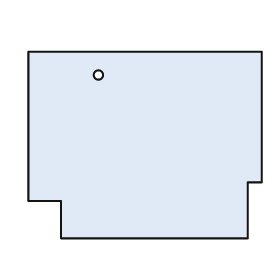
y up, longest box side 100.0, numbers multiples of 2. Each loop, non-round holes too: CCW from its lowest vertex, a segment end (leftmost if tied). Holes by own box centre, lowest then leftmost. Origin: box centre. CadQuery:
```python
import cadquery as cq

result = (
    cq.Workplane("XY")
    .moveTo(-36.0, -40.0)
    .lineTo(44.0, -40.0)
    .lineTo(44.0, -16.0)
    .lineTo(50.0, -16.0)
    .lineTo(50.0, 40.0)
    .lineTo(-50.0, 40.0)
    .lineTo(-50.0, -24.0)
    .lineTo(-36.0, -24.0)
    .close()
    .moveTo(-20.0, 30.0)
    .circle(2.0)
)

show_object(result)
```